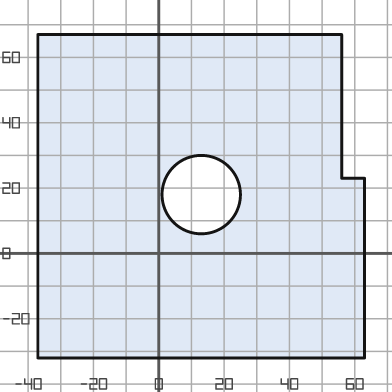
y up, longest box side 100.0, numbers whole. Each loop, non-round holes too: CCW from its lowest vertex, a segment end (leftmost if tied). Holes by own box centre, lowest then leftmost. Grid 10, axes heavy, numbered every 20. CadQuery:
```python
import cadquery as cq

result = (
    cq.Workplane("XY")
    .moveTo(-37.0, -32.0)
    .lineTo(63.0, -32.0)
    .lineTo(63.0, 23.0)
    .lineTo(56.0, 23.0)
    .lineTo(56.0, 67.0)
    .lineTo(-37.0, 67.0)
    .close()
    .moveTo(13.0, 18.0)
    .circle(12.0)
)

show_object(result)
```